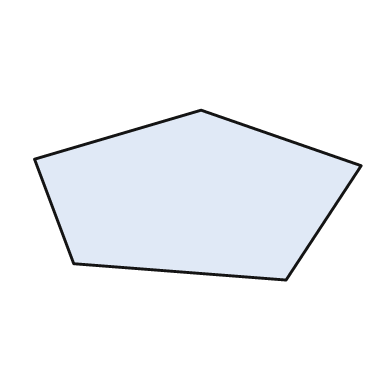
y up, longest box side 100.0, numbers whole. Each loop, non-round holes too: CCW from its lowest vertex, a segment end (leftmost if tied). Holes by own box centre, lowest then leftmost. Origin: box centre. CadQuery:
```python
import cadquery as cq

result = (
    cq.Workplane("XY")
    .moveTo(27.0, -26.0)
    .lineTo(50.0, 9.0)
    .lineTo(1.0, 26.0)
    .lineTo(-50.0, 11.0)
    .lineTo(-38.0, -21.0)
    .close()
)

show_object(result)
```